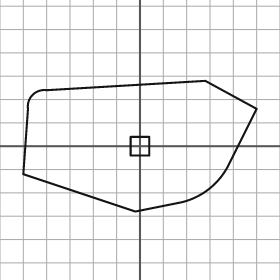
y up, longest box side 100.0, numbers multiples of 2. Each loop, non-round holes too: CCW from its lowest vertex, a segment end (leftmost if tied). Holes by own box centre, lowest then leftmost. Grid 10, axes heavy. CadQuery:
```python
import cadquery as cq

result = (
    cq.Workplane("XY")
    .moveTo(-2.0, -28.0)
    .lineTo(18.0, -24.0)
    .threePointArc((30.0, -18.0), (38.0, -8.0))
    .lineTo(50.0, 16.0)
    .lineTo(28.0, 28.0)
    .lineTo(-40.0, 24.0)
    .threePointArc((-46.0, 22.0), (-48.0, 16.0))
    .lineTo(-50.0, -12.0)
    .close()
    .moveTo(-4.0, -4.0)
    .lineTo(4.0, -4.0)
    .lineTo(4.0, 4.0)
    .lineTo(-4.0, 4.0)
    .close()
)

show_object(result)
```